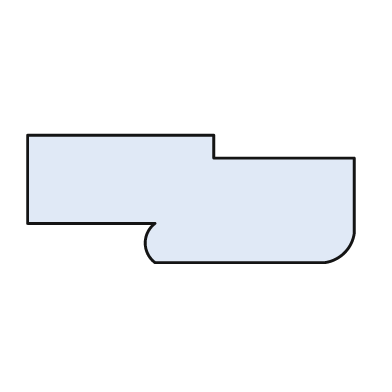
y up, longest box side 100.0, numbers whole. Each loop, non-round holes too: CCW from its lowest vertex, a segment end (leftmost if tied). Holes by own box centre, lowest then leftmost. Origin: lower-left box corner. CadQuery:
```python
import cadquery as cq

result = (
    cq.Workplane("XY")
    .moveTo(39.0, 0.0)
    .lineTo(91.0, 0.0)
    .threePointArc((97.0, 3.0), (100.0, 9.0))
    .lineTo(100.0, 32.0)
    .lineTo(57.0, 32.0)
    .lineTo(57.0, 39.0)
    .lineTo(0.0, 39.0)
    .lineTo(0.0, 12.0)
    .lineTo(39.0, 12.0)
    .threePointArc((36.0, 6.0), (39.0, 0.0))
    .close()
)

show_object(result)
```